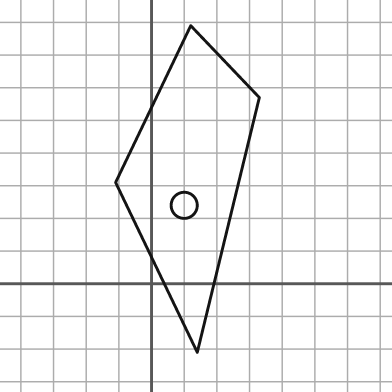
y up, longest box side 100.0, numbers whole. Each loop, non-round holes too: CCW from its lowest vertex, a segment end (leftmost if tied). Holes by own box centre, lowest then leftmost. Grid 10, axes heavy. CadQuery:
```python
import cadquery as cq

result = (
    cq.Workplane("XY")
    .moveTo(14.0, -21.0)
    .lineTo(33.0, 57.0)
    .lineTo(12.0, 79.0)
    .lineTo(-11.0, 31.0)
    .close()
    .moveTo(10.0, 24.0)
    .circle(4.0)
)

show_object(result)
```